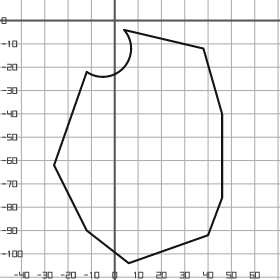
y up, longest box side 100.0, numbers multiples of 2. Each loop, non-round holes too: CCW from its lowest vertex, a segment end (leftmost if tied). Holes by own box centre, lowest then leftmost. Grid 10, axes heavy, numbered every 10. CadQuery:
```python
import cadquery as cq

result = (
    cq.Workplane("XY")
    .moveTo(6.0, -104.0)
    .lineTo(40.0, -92.0)
    .lineTo(46.0, -76.0)
    .lineTo(46.0, -40.0)
    .lineTo(38.0, -12.0)
    .lineTo(4.0, -4.0)
    .threePointArc((4.0, -20.0), (-12.0, -22.0))
    .lineTo(-26.0, -62.0)
    .lineTo(-12.0, -90.0)
    .close()
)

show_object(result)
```